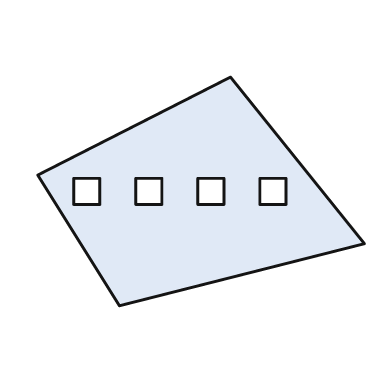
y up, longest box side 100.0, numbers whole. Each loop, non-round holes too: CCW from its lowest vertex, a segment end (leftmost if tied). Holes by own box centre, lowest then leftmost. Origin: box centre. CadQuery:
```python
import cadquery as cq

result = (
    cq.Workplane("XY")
    .moveTo(-25.0, -35.0)
    .lineTo(50.0, -16.0)
    .lineTo(9.0, 35.0)
    .lineTo(-50.0, 5.0)
    .close()
    .moveTo(-39.0, -4.0)
    .lineTo(-31.0, -4.0)
    .lineTo(-31.0, 4.0)
    .lineTo(-39.0, 4.0)
    .close()
    .moveTo(-20.0, -4.0)
    .lineTo(-12.0, -4.0)
    .lineTo(-12.0, 4.0)
    .lineTo(-20.0, 4.0)
    .close()
    .moveTo(-1.0, -4.0)
    .lineTo(7.0, -4.0)
    .lineTo(7.0, 4.0)
    .lineTo(-1.0, 4.0)
    .close()
    .moveTo(18.0, -4.0)
    .lineTo(26.0, -4.0)
    .lineTo(26.0, 4.0)
    .lineTo(18.0, 4.0)
    .close()
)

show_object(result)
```